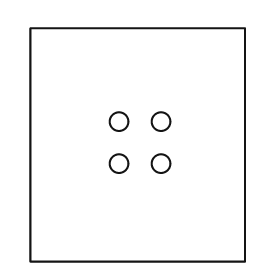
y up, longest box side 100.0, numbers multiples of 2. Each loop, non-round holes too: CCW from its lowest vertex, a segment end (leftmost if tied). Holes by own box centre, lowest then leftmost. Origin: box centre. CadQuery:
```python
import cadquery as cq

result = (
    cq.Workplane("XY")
    .moveTo(-46.0, -50.0)
    .lineTo(46.0, -50.0)
    .lineTo(46.0, 50.0)
    .lineTo(-46.0, 50.0)
    .close()
    .moveTo(-8.0, -8.0)
    .circle(4.0)
    .moveTo(10.0, -8.0)
    .circle(4.0)
    .moveTo(-8.0, 10.0)
    .circle(4.0)
    .moveTo(10.0, 10.0)
    .circle(4.0)
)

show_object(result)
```